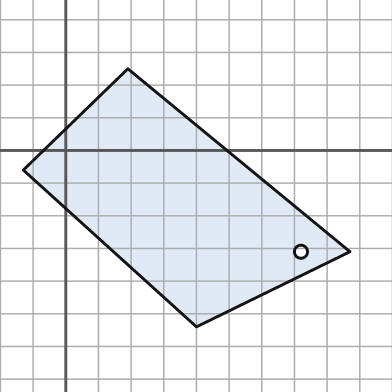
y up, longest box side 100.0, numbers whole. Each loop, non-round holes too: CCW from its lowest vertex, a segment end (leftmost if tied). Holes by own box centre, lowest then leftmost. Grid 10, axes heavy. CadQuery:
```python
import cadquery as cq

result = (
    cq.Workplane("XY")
    .moveTo(40.0, -54.0)
    .lineTo(87.0, -31.0)
    .lineTo(19.0, 25.0)
    .lineTo(-13.0, -6.0)
    .close()
    .moveTo(72.0, -31.0)
    .circle(2.0)
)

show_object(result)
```